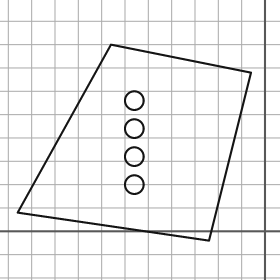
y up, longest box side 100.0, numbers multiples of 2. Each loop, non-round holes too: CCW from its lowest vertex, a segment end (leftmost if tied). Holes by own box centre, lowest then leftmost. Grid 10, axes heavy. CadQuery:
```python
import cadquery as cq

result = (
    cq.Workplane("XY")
    .moveTo(-24.0, -4.0)
    .lineTo(-6.0, 68.0)
    .lineTo(-66.0, 80.0)
    .lineTo(-106.0, 8.0)
    .close()
    .moveTo(-56.0, 20.0)
    .circle(4.0)
    .moveTo(-56.0, 32.0)
    .circle(4.0)
    .moveTo(-56.0, 44.0)
    .circle(4.0)
    .moveTo(-56.0, 56.0)
    .circle(4.0)
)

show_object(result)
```